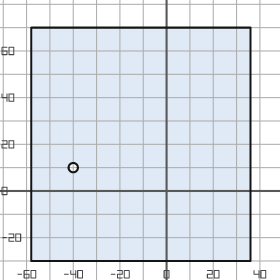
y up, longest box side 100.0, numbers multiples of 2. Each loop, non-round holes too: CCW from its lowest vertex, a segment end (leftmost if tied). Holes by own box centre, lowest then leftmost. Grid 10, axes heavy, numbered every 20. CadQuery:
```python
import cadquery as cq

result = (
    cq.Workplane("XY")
    .moveTo(-58.0, -30.0)
    .lineTo(36.0, -30.0)
    .lineTo(36.0, 70.0)
    .lineTo(-58.0, 70.0)
    .close()
    .moveTo(-40.0, 10.0)
    .circle(2.0)
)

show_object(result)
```